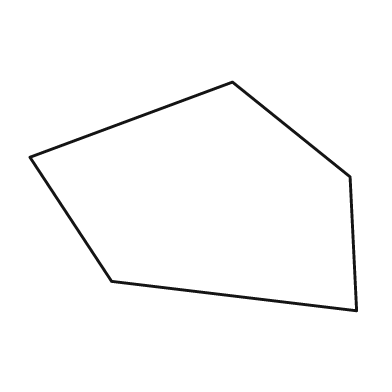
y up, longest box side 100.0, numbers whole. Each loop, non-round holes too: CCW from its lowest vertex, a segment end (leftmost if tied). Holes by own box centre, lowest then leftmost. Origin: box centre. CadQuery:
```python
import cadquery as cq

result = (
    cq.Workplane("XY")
    .moveTo(50.0, -35.0)
    .lineTo(48.0, 6.0)
    .lineTo(12.0, 35.0)
    .lineTo(-50.0, 12.0)
    .lineTo(-25.0, -26.0)
    .close()
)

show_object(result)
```